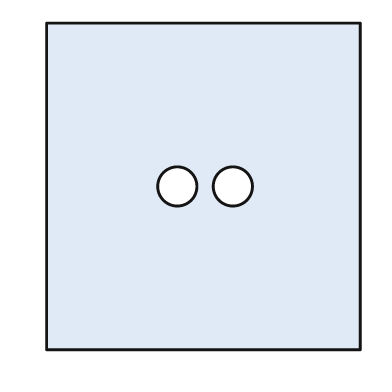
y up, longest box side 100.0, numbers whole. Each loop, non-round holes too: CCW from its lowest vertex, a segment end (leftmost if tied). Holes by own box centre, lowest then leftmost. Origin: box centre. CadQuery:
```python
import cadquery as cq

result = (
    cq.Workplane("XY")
    .moveTo(-48.0, -50.0)
    .lineTo(48.0, -50.0)
    .lineTo(48.0, 50.0)
    .lineTo(-48.0, 50.0)
    .close()
    .moveTo(-8.0, 0.0)
    .circle(6.0)
    .moveTo(9.0, 0.0)
    .circle(6.0)
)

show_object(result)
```